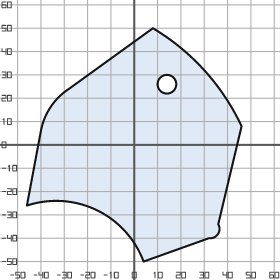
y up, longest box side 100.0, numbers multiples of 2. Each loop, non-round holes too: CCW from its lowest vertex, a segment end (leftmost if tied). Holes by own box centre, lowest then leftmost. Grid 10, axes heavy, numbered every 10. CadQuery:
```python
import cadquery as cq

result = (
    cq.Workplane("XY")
    .moveTo(4.0, -50.0)
    .lineTo(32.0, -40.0)
    .threePointArc((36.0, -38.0), (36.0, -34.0))
    .lineTo(46.0, 8.0)
    .threePointArc((30.0, 32.0), (8.0, 50.0))
    .lineTo(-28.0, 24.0)
    .threePointArc((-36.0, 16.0), (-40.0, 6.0))
    .lineTo(-46.0, -26.0)
    .threePointArc((-16.0, -28.0), (4.0, -50.0))
    .close()
    .moveTo(14.0, 26.0)
    .circle(4.0)
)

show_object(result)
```